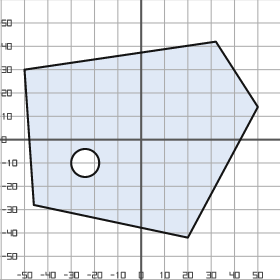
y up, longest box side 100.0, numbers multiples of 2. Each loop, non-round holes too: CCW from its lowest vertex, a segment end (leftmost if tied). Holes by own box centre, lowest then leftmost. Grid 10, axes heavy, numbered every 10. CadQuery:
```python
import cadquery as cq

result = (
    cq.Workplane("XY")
    .moveTo(20.0, -42.0)
    .lineTo(50.0, 14.0)
    .lineTo(32.0, 42.0)
    .lineTo(-50.0, 30.0)
    .lineTo(-46.0, -28.0)
    .close()
    .moveTo(-24.0, -10.0)
    .circle(6.0)
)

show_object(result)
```